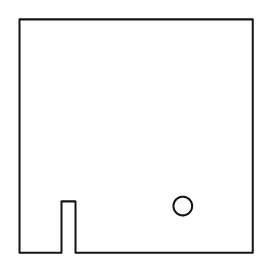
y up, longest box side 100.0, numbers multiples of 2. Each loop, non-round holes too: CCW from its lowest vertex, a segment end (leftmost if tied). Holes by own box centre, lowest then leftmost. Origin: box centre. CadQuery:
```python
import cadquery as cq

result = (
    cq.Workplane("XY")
    .moveTo(-50.0, -50.0)
    .lineTo(-32.0, -50.0)
    .lineTo(-32.0, -28.0)
    .lineTo(-26.0, -28.0)
    .lineTo(-26.0, -50.0)
    .lineTo(50.0, -50.0)
    .lineTo(50.0, 50.0)
    .lineTo(-50.0, 50.0)
    .close()
    .moveTo(20.0, -30.0)
    .circle(4.0)
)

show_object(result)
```